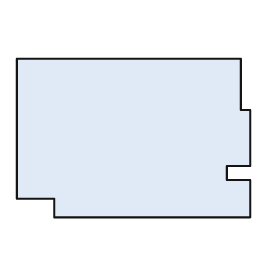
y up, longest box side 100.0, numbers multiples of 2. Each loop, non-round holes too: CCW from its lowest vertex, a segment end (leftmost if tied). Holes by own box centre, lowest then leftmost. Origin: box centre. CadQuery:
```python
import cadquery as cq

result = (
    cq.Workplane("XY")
    .moveTo(-34.0, -34.0)
    .lineTo(50.0, -34.0)
    .lineTo(50.0, -18.0)
    .lineTo(40.0, -18.0)
    .lineTo(40.0, -12.0)
    .lineTo(50.0, -12.0)
    .lineTo(50.0, 12.0)
    .lineTo(46.0, 12.0)
    .lineTo(46.0, 34.0)
    .lineTo(-50.0, 34.0)
    .lineTo(-50.0, -26.0)
    .lineTo(-34.0, -26.0)
    .close()
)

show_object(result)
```